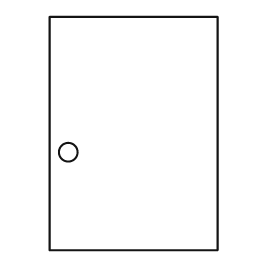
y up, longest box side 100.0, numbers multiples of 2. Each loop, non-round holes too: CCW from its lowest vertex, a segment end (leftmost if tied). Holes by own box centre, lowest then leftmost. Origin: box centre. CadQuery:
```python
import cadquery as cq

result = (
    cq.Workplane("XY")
    .moveTo(-36.0, -50.0)
    .lineTo(36.0, -50.0)
    .lineTo(36.0, 50.0)
    .lineTo(-36.0, 50.0)
    .close()
    .moveTo(-28.0, -8.0)
    .circle(4.0)
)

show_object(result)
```